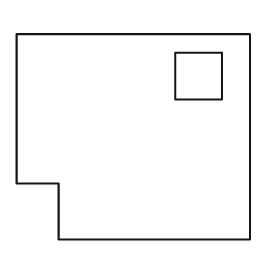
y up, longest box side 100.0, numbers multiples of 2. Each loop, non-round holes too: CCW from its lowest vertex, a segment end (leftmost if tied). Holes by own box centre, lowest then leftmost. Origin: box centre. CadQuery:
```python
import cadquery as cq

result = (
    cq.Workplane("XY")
    .moveTo(-32.0, -44.0)
    .lineTo(50.0, -44.0)
    .lineTo(50.0, 44.0)
    .lineTo(-50.0, 44.0)
    .lineTo(-50.0, -20.0)
    .lineTo(-32.0, -20.0)
    .close()
    .moveTo(18.0, 16.0)
    .lineTo(38.0, 16.0)
    .lineTo(38.0, 36.0)
    .lineTo(18.0, 36.0)
    .close()
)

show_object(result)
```